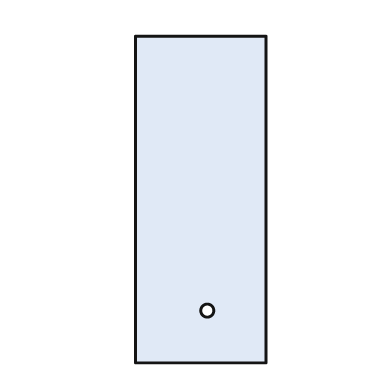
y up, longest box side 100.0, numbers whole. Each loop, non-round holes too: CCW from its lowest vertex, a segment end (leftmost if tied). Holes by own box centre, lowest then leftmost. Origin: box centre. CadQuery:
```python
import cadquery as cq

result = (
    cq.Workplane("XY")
    .moveTo(-20.0, -50.0)
    .lineTo(20.0, -50.0)
    .lineTo(20.0, 50.0)
    .lineTo(-20.0, 50.0)
    .close()
    .moveTo(2.0, -34.0)
    .circle(2.0)
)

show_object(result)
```